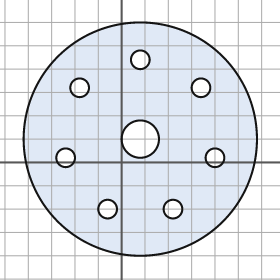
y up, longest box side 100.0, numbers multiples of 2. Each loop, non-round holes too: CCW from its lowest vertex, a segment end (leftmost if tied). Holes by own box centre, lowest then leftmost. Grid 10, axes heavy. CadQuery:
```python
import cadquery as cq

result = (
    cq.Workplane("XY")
    .moveTo(8.0, 10.0)
    .circle(50.0)
    .moveTo(-6.0, -20.0)
    .circle(4.0)
    .moveTo(22.0, -20.0)
    .circle(4.0)
    .moveTo(-24.0, 2.0)
    .circle(4.0)
    .moveTo(40.0, 2.0)
    .circle(4.0)
    .moveTo(8.0, 10.0)
    .circle(8.0)
    .moveTo(-18.0, 32.0)
    .circle(4.0)
    .moveTo(34.0, 32.0)
    .circle(4.0)
    .moveTo(8.0, 44.0)
    .circle(4.0)
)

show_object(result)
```